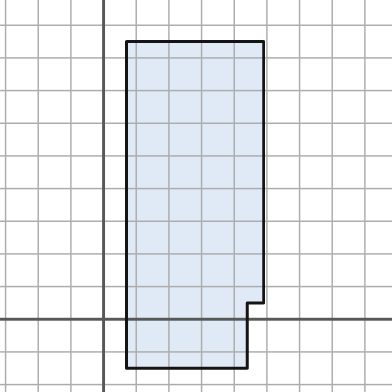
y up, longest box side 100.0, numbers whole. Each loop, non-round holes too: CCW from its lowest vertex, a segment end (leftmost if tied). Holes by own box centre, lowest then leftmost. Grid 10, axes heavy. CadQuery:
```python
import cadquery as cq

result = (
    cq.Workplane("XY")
    .moveTo(7.0, -15.0)
    .lineTo(44.0, -15.0)
    .lineTo(44.0, 5.0)
    .lineTo(49.0, 5.0)
    .lineTo(49.0, 85.0)
    .lineTo(7.0, 85.0)
    .close()
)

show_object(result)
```